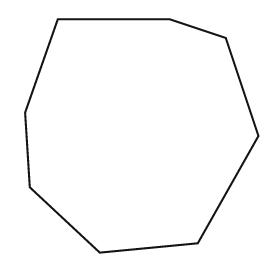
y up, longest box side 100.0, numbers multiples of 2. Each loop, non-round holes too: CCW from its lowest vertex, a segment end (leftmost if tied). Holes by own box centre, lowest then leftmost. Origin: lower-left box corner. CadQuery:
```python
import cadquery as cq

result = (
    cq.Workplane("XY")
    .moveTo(32.0, 0.0)
    .lineTo(74.0, 4.0)
    .lineTo(100.0, 50.0)
    .lineTo(86.0, 92.0)
    .lineTo(62.0, 100.0)
    .lineTo(14.0, 100.0)
    .lineTo(0.0, 60.0)
    .lineTo(2.0, 28.0)
    .close()
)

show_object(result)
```